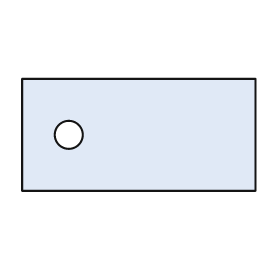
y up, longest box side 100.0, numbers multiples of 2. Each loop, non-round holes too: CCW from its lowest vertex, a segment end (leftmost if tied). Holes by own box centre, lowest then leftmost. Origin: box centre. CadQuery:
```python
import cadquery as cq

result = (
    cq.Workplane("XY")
    .moveTo(-50.0, -24.0)
    .lineTo(50.0, -24.0)
    .lineTo(50.0, 24.0)
    .lineTo(-50.0, 24.0)
    .close()
    .moveTo(-30.0, 0.0)
    .circle(6.0)
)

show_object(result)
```